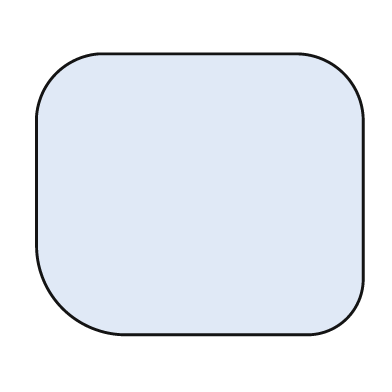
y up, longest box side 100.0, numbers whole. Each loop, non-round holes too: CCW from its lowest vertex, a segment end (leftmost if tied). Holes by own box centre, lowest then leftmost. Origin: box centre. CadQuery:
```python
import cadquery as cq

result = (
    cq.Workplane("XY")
    .moveTo(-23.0, -43.0)
    .lineTo(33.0, -43.0)
    .threePointArc((45.0, -38.0), (50.0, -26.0))
    .lineTo(50.0, 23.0)
    .threePointArc((44.0, 37.0), (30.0, 43.0))
    .lineTo(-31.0, 43.0)
    .threePointArc((-44.0, 37.0), (-50.0, 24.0))
    .lineTo(-50.0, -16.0)
    .threePointArc((-42.0, -35.0), (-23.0, -43.0))
    .close()
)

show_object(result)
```